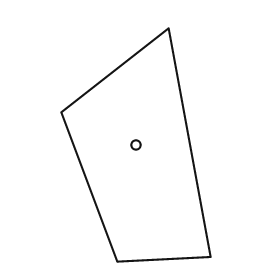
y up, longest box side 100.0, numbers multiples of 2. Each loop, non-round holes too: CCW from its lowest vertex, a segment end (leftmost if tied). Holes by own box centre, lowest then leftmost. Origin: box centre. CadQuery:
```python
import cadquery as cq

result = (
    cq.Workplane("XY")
    .moveTo(-8.0, -50.0)
    .lineTo(32.0, -48.0)
    .lineTo(14.0, 50.0)
    .lineTo(-32.0, 14.0)
    .close()
    .moveTo(0.0, 0.0)
    .circle(2.0)
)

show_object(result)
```